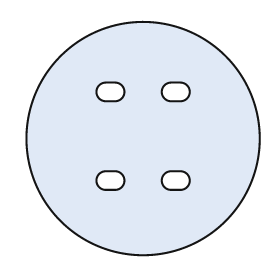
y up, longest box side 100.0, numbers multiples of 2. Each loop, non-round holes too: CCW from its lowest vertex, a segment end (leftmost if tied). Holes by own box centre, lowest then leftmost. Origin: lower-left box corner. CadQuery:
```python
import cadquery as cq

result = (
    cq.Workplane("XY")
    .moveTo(50.0, 50.0)
    .circle(50.0)
    .moveTo(34.0, 28.0)
    .lineTo(38.0, 28.0)
    .threePointArc((42.0, 32.0), (38.0, 36.0))
    .lineTo(34.0, 36.0)
    .threePointArc((30.0, 32.0), (34.0, 28.0))
    .close()
    .moveTo(62.0, 28.0)
    .lineTo(66.0, 28.0)
    .threePointArc((70.0, 32.0), (66.0, 36.0))
    .lineTo(62.0, 36.0)
    .threePointArc((58.0, 32.0), (62.0, 28.0))
    .close()
    .moveTo(34.0, 66.0)
    .lineTo(38.0, 66.0)
    .threePointArc((42.0, 70.0), (38.0, 74.0))
    .lineTo(34.0, 74.0)
    .threePointArc((30.0, 70.0), (34.0, 66.0))
    .close()
    .moveTo(62.0, 66.0)
    .lineTo(66.0, 66.0)
    .threePointArc((70.0, 70.0), (66.0, 74.0))
    .lineTo(62.0, 74.0)
    .threePointArc((58.0, 70.0), (62.0, 66.0))
    .close()
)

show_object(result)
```